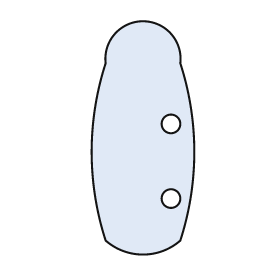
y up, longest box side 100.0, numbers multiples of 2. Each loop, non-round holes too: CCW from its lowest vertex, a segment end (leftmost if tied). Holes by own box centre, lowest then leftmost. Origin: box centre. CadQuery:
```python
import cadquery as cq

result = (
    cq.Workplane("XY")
    .moveTo(-16.0, -44.0)
    .threePointArc((0.0, -50.0), (16.0, -44.0))
    .threePointArc((22.0, -6.0), (16.0, 32.0))
    .threePointArc((0.0, 50.0), (-16.0, 32.0))
    .threePointArc((-22.0, -6.0), (-16.0, -44.0))
    .close()
    .moveTo(12.0, -26.0)
    .circle(4.0)
    .moveTo(12.0, 6.0)
    .circle(4.0)
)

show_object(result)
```